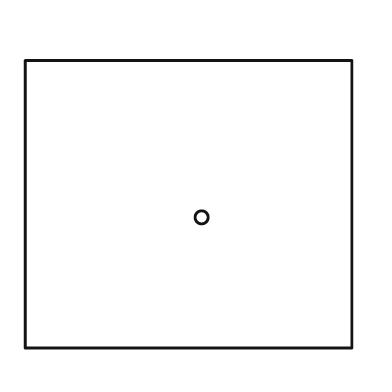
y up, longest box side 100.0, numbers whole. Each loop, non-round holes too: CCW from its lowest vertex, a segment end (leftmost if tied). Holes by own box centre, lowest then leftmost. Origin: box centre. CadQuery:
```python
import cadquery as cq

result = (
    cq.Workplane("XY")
    .moveTo(-50.0, -44.0)
    .lineTo(50.0, -44.0)
    .lineTo(50.0, 44.0)
    .lineTo(-50.0, 44.0)
    .close()
    .moveTo(4.0, -4.0)
    .circle(2.0)
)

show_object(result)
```